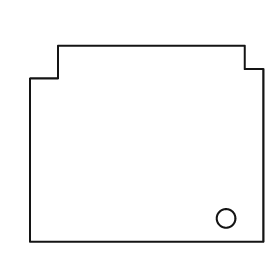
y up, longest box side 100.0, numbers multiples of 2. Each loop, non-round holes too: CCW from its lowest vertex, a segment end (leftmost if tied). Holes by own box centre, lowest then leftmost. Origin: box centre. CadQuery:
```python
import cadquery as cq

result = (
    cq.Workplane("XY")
    .moveTo(-50.0, -42.0)
    .lineTo(50.0, -42.0)
    .lineTo(50.0, 32.0)
    .lineTo(42.0, 32.0)
    .lineTo(42.0, 42.0)
    .lineTo(-38.0, 42.0)
    .lineTo(-38.0, 28.0)
    .lineTo(-50.0, 28.0)
    .close()
    .moveTo(34.0, -32.0)
    .circle(4.0)
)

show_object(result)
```